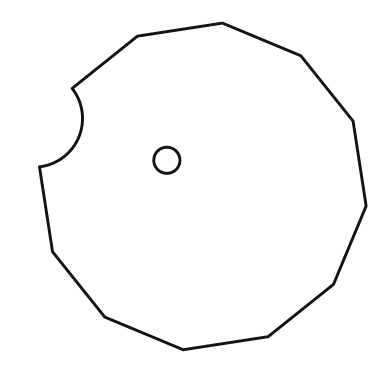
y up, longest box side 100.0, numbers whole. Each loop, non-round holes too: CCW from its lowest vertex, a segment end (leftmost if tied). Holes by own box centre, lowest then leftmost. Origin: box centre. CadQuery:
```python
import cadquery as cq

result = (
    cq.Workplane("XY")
    .moveTo(-6.0, -50.0)
    .lineTo(20.0, -46.0)
    .lineTo(40.0, -30.0)
    .lineTo(50.0, -6.0)
    .lineTo(46.0, 20.0)
    .lineTo(30.0, 40.0)
    .lineTo(6.0, 50.0)
    .lineTo(-20.0, 46.0)
    .lineTo(-40.0, 30.0)
    .threePointArc((-38.0, 15.0), (-50.0, 6.0))
    .lineTo(-46.0, -20.0)
    .lineTo(-30.0, -40.0)
    .close()
    .moveTo(-11.0, 8.0)
    .circle(4.0)
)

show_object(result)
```